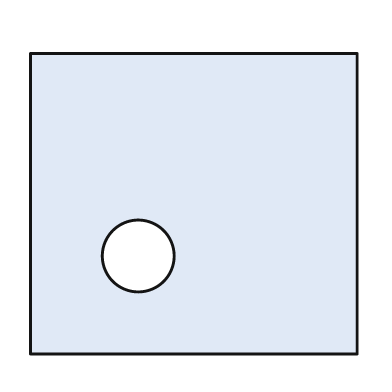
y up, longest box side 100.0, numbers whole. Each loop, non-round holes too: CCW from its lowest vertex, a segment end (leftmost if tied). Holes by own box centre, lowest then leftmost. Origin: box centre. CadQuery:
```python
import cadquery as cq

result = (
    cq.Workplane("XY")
    .moveTo(-50.0, -46.0)
    .lineTo(50.0, -46.0)
    .lineTo(50.0, 46.0)
    .lineTo(-50.0, 46.0)
    .close()
    .moveTo(-17.0, -16.0)
    .circle(11.0)
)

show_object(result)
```